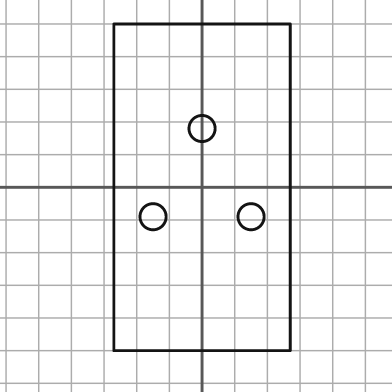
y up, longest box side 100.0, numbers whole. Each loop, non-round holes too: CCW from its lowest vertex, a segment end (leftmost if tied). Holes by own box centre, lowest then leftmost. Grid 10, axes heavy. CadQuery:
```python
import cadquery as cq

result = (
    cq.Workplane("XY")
    .moveTo(-27.0, -50.0)
    .lineTo(27.0, -50.0)
    .lineTo(27.0, 50.0)
    .lineTo(-27.0, 50.0)
    .close()
    .moveTo(-15.0, -9.0)
    .circle(4.0)
    .moveTo(15.0, -9.0)
    .circle(4.0)
    .moveTo(0.0, 18.0)
    .circle(4.0)
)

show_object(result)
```